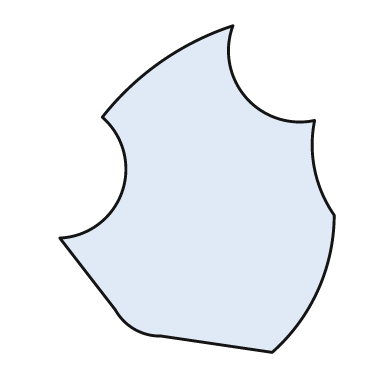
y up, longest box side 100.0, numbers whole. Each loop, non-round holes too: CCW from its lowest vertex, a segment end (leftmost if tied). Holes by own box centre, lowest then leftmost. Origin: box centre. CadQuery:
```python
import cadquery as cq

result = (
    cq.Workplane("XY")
    .moveTo(23.0, -50.0)
    .threePointArc((37.0, -31.0), (42.0, -8.0))
    .threePointArc((36.0, 6.0), (36.0, 21.0))
    .threePointArc((15.0, 28.0), (11.0, 50.0))
    .threePointArc((-11.0, 39.0), (-29.0, 22.0))
    .threePointArc((-23.0, -1.0), (-42.0, -15.0))
    .lineTo(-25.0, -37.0)
    .threePointArc((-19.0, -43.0), (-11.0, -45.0))
    .close()
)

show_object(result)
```